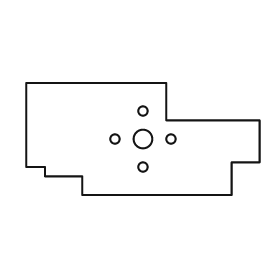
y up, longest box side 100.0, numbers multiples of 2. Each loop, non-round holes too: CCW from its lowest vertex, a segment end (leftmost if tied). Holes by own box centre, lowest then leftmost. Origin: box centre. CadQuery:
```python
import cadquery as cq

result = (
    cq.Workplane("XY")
    .moveTo(-26.0, -24.0)
    .lineTo(38.0, -24.0)
    .lineTo(38.0, -10.0)
    .lineTo(50.0, -10.0)
    .lineTo(50.0, 8.0)
    .lineTo(10.0, 8.0)
    .lineTo(10.0, 24.0)
    .lineTo(-50.0, 24.0)
    .lineTo(-50.0, -12.0)
    .lineTo(-42.0, -12.0)
    .lineTo(-42.0, -16.0)
    .lineTo(-26.0, -16.0)
    .close()
    .moveTo(0.0, -12.0)
    .circle(2.0)
    .moveTo(-12.0, 0.0)
    .circle(2.0)
    .moveTo(0.0, 0.0)
    .circle(4.0)
    .moveTo(12.0, 0.0)
    .circle(2.0)
    .moveTo(0.0, 12.0)
    .circle(2.0)
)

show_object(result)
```